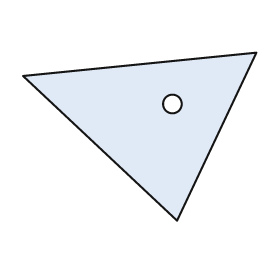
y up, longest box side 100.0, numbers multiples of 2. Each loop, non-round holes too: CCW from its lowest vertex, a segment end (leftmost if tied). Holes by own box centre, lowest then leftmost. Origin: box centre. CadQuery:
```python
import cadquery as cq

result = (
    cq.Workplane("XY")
    .moveTo(16.0, -36.0)
    .lineTo(50.0, 36.0)
    .lineTo(-50.0, 26.0)
    .close()
    .moveTo(14.0, 14.0)
    .circle(4.0)
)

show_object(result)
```